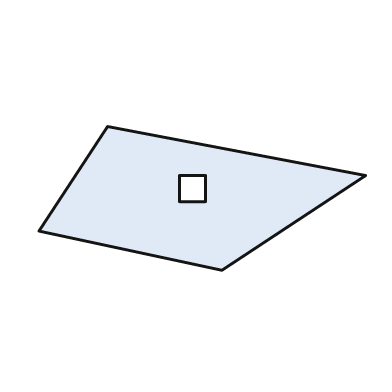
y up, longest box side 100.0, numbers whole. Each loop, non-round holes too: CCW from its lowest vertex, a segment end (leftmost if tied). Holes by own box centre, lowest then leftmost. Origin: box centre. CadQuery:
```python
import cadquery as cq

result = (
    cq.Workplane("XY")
    .moveTo(6.0, -22.0)
    .lineTo(50.0, 7.0)
    .lineTo(-29.0, 22.0)
    .lineTo(-50.0, -10.0)
    .close()
    .moveTo(-7.0, -1.0)
    .lineTo(1.0, -1.0)
    .lineTo(1.0, 7.0)
    .lineTo(-7.0, 7.0)
    .close()
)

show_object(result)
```